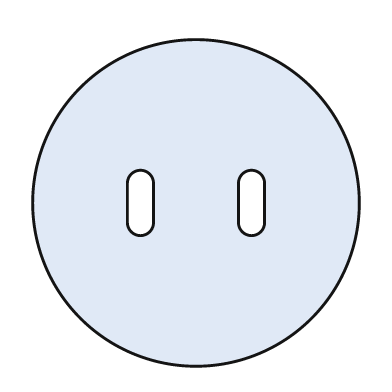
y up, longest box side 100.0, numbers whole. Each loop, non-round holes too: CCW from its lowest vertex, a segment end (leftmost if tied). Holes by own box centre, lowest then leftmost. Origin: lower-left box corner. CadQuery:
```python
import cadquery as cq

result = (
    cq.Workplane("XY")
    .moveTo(50.0, 50.0)
    .circle(50.0)
    .moveTo(29.0, 44.0)
    .threePointArc((33.0, 40.0), (37.0, 44.0))
    .lineTo(37.0, 56.0)
    .threePointArc((33.0, 60.0), (29.0, 56.0))
    .close()
    .moveTo(63.0, 44.0)
    .threePointArc((67.0, 40.0), (71.0, 44.0))
    .lineTo(71.0, 56.0)
    .threePointArc((67.0, 60.0), (63.0, 56.0))
    .close()
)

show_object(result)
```